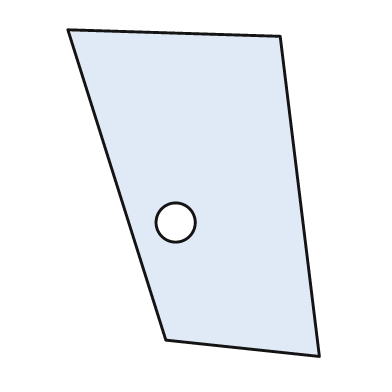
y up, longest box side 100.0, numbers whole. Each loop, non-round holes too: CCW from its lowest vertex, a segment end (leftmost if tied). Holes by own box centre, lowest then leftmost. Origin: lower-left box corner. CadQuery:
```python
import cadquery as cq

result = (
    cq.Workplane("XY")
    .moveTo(77.0, 0.0)
    .lineTo(65.0, 98.0)
    .lineTo(0.0, 100.0)
    .lineTo(30.0, 5.0)
    .close()
    .moveTo(33.0, 41.0)
    .circle(6.0)
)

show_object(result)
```